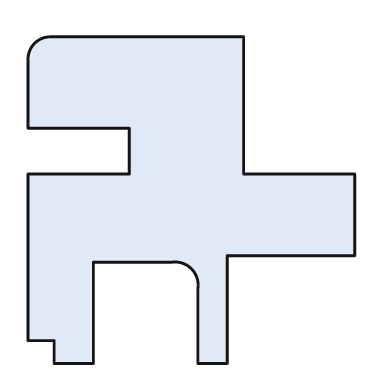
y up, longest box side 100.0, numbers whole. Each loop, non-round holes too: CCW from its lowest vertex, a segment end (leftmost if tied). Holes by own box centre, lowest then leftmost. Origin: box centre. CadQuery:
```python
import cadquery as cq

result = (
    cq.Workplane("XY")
    .moveTo(-42.0, -50.0)
    .lineTo(-30.0, -50.0)
    .lineTo(-30.0, -19.0)
    .lineTo(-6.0, -19.0)
    .threePointArc((0.0, -21.0), (2.0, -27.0))
    .lineTo(2.0, -50.0)
    .lineTo(11.0, -50.0)
    .lineTo(11.0, -17.0)
    .lineTo(50.0, -17.0)
    .lineTo(50.0, 8.0)
    .lineTo(16.0, 8.0)
    .lineTo(16.0, 50.0)
    .lineTo(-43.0, 50.0)
    .threePointArc((-48.0, 48.0), (-50.0, 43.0))
    .lineTo(-50.0, 22.0)
    .lineTo(-19.0, 22.0)
    .lineTo(-19.0, 8.0)
    .lineTo(-50.0, 8.0)
    .lineTo(-50.0, -43.0)
    .lineTo(-42.0, -43.0)
    .close()
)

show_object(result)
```